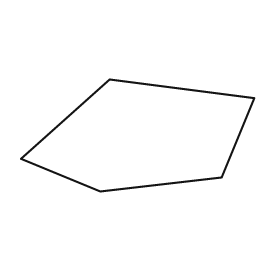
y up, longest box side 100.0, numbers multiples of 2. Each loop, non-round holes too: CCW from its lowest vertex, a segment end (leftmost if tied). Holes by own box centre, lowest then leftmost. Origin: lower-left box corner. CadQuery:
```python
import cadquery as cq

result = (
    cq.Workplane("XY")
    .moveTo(34.0, 0.0)
    .lineTo(86.0, 6.0)
    .lineTo(100.0, 40.0)
    .lineTo(38.0, 48.0)
    .lineTo(0.0, 14.0)
    .close()
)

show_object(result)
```